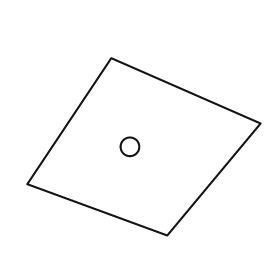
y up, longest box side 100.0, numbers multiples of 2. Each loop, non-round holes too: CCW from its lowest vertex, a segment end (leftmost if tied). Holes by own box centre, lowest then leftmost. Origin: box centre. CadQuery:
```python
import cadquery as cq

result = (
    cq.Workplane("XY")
    .moveTo(10.0, -38.0)
    .lineTo(50.0, 10.0)
    .lineTo(-14.0, 38.0)
    .lineTo(-50.0, -16.0)
    .close()
    .moveTo(-6.0, 0.0)
    .circle(4.0)
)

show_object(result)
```